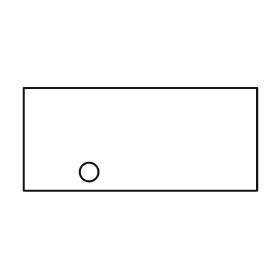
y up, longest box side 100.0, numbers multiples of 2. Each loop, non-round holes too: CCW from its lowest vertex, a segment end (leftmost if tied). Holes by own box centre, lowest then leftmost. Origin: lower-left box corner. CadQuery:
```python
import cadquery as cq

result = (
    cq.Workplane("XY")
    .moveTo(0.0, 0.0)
    .lineTo(100.0, 0.0)
    .lineTo(100.0, 44.0)
    .lineTo(0.0, 44.0)
    .close()
    .moveTo(28.0, 8.0)
    .circle(4.0)
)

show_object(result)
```